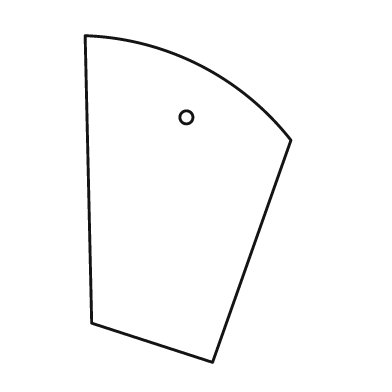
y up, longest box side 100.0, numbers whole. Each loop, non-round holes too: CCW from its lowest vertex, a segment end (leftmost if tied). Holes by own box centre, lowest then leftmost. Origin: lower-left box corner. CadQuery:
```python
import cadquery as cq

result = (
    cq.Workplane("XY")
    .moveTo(39.0, 0.0)
    .lineTo(63.0, 68.0)
    .threePointArc((35.0, 91.0), (0.0, 100.0))
    .lineTo(2.0, 12.0)
    .close()
    .moveTo(31.0, 75.0)
    .circle(2.0)
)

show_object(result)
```